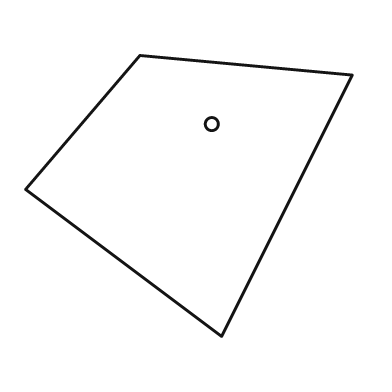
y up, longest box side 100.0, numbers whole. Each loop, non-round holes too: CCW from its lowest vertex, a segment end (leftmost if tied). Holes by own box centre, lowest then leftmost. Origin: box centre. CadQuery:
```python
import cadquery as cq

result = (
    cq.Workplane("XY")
    .moveTo(10.0, -43.0)
    .lineTo(50.0, 37.0)
    .lineTo(-15.0, 43.0)
    .lineTo(-50.0, 2.0)
    .close()
    .moveTo(7.0, 22.0)
    .circle(2.0)
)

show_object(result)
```